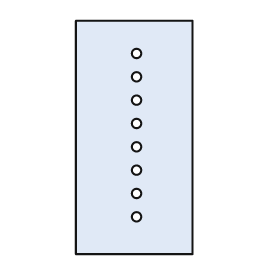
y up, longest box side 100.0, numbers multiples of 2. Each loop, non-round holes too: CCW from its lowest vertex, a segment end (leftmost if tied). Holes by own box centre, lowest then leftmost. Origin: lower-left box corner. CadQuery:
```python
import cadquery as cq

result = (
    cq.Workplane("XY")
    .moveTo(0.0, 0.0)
    .lineTo(50.0, 0.0)
    .lineTo(50.0, 100.0)
    .lineTo(0.0, 100.0)
    .close()
    .moveTo(26.0, 16.0)
    .circle(2.0)
    .moveTo(26.0, 26.0)
    .circle(2.0)
    .moveTo(26.0, 36.0)
    .circle(2.0)
    .moveTo(26.0, 46.0)
    .circle(2.0)
    .moveTo(26.0, 56.0)
    .circle(2.0)
    .moveTo(26.0, 66.0)
    .circle(2.0)
    .moveTo(26.0, 76.0)
    .circle(2.0)
    .moveTo(26.0, 86.0)
    .circle(2.0)
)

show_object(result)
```